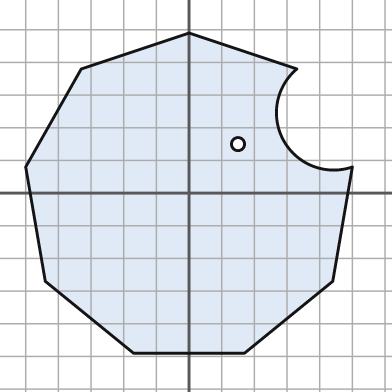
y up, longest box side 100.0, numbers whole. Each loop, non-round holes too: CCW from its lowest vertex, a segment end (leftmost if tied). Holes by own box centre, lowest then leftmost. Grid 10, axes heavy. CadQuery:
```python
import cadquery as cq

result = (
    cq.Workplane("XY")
    .moveTo(-17.0, -49.0)
    .lineTo(17.0, -49.0)
    .lineTo(44.0, -27.0)
    .lineTo(50.0, 8.0)
    .threePointArc((29.0, 16.0), (33.0, 38.0))
    .lineTo(0.0, 49.0)
    .lineTo(-33.0, 38.0)
    .lineTo(-50.0, 8.0)
    .lineTo(-44.0, -27.0)
    .close()
    .moveTo(15.0, 15.0)
    .circle(2.0)
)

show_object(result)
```